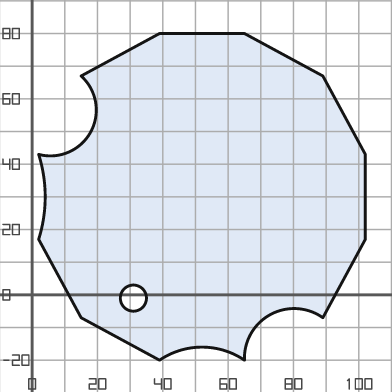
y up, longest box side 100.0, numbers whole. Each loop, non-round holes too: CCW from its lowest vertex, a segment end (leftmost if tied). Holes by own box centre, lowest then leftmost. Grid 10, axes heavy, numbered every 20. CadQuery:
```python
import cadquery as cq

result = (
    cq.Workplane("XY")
    .moveTo(39.0, -20.0)
    .threePointArc((52.0, -16.0), (65.0, -20.0))
    .threePointArc((73.0, -6.0), (89.0, -7.0))
    .lineTo(102.0, 17.0)
    .lineTo(102.0, 43.0)
    .lineTo(89.0, 67.0)
    .lineTo(65.0, 80.0)
    .lineTo(39.0, 80.0)
    .lineTo(15.0, 67.0)
    .threePointArc((18.0, 50.0), (2.0, 43.0))
    .threePointArc((4.0, 30.0), (2.0, 17.0))
    .lineTo(15.0, -7.0)
    .close()
    .moveTo(31.0, -1.0)
    .circle(4.0)
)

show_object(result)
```